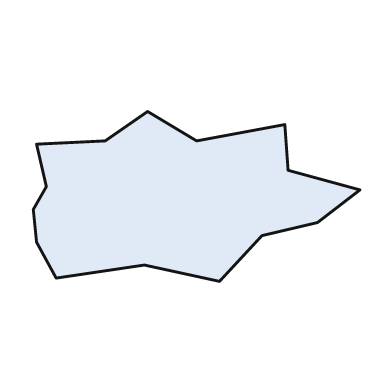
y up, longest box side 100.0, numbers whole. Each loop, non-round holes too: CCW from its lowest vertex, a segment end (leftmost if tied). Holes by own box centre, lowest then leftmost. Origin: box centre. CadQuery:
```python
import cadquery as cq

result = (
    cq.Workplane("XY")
    .moveTo(7.0, -26.0)
    .lineTo(20.0, -12.0)
    .lineTo(37.0, -8.0)
    .lineTo(50.0, 2.0)
    .lineTo(28.0, 8.0)
    .lineTo(27.0, 22.0)
    .lineTo(0.0, 17.0)
    .lineTo(-15.0, 26.0)
    .lineTo(-28.0, 17.0)
    .lineTo(-49.0, 16.0)
    .lineTo(-46.0, 3.0)
    .lineTo(-50.0, -4.0)
    .lineTo(-49.0, -14.0)
    .lineTo(-43.0, -25.0)
    .lineTo(-16.0, -21.0)
    .close()
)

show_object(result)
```